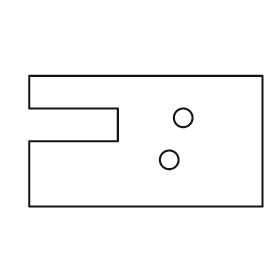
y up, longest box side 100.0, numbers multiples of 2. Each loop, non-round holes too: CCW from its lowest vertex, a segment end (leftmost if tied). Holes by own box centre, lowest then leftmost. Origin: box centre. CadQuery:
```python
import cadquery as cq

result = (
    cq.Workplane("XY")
    .moveTo(-50.0, -28.0)
    .lineTo(50.0, -28.0)
    .lineTo(50.0, 28.0)
    .lineTo(-50.0, 28.0)
    .lineTo(-50.0, 14.0)
    .lineTo(-12.0, 14.0)
    .lineTo(-12.0, 0.0)
    .lineTo(-50.0, 0.0)
    .close()
    .moveTo(10.0, -8.0)
    .circle(4.0)
    .moveTo(16.0, 10.0)
    .circle(4.0)
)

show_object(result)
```